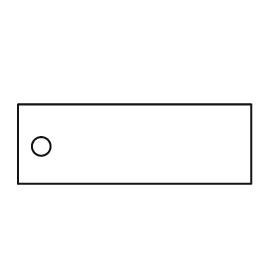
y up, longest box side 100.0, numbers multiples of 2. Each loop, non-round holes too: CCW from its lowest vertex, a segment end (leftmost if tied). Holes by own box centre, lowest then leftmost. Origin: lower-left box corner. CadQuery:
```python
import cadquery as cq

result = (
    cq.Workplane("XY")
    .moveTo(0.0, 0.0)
    .lineTo(100.0, 0.0)
    .lineTo(100.0, 34.0)
    .lineTo(0.0, 34.0)
    .close()
    .moveTo(10.0, 16.0)
    .circle(4.0)
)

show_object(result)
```